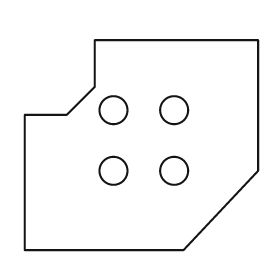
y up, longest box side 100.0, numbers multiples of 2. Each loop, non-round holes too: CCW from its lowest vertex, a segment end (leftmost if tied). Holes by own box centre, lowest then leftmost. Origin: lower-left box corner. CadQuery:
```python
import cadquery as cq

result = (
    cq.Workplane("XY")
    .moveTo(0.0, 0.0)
    .lineTo(68.0, 0.0)
    .lineTo(100.0, 34.0)
    .lineTo(100.0, 90.0)
    .lineTo(30.0, 90.0)
    .lineTo(30.0, 70.0)
    .lineTo(18.0, 58.0)
    .lineTo(0.0, 58.0)
    .close()
    .moveTo(38.0, 34.0)
    .circle(6.0)
    .moveTo(64.0, 34.0)
    .circle(6.0)
    .moveTo(38.0, 60.0)
    .circle(6.0)
    .moveTo(64.0, 60.0)
    .circle(6.0)
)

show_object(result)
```